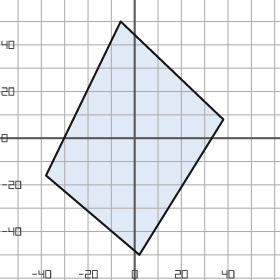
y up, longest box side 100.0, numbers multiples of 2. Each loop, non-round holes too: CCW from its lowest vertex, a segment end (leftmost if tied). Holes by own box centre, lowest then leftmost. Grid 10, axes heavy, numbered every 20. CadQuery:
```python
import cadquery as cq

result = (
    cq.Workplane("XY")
    .moveTo(2.0, -50.0)
    .lineTo(38.0, 8.0)
    .lineTo(-6.0, 50.0)
    .lineTo(-38.0, -16.0)
    .close()
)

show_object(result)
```